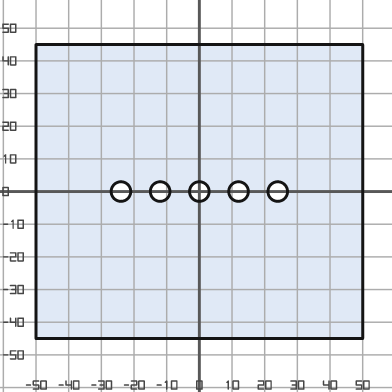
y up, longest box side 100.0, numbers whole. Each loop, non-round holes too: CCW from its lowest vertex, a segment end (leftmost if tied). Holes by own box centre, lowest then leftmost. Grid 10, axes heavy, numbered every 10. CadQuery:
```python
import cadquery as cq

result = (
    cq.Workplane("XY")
    .moveTo(-50.0, -45.0)
    .lineTo(50.0, -45.0)
    .lineTo(50.0, 45.0)
    .lineTo(-50.0, 45.0)
    .close()
    .moveTo(-24.0, 0.0)
    .circle(3.0)
    .moveTo(-12.0, 0.0)
    .circle(3.0)
    .moveTo(0.0, 0.0)
    .circle(3.0)
    .moveTo(12.0, 0.0)
    .circle(3.0)
    .moveTo(24.0, 0.0)
    .circle(3.0)
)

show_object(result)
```